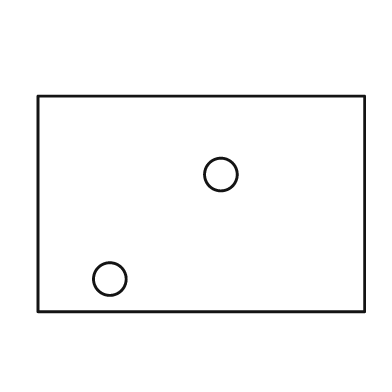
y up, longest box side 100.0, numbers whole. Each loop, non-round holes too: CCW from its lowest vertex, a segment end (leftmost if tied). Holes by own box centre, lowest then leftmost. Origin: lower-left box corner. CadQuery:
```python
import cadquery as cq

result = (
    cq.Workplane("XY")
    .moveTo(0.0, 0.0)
    .lineTo(100.0, 0.0)
    .lineTo(100.0, 66.0)
    .lineTo(0.0, 66.0)
    .close()
    .moveTo(22.0, 10.0)
    .circle(5.0)
    .moveTo(56.0, 42.0)
    .circle(5.0)
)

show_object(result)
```